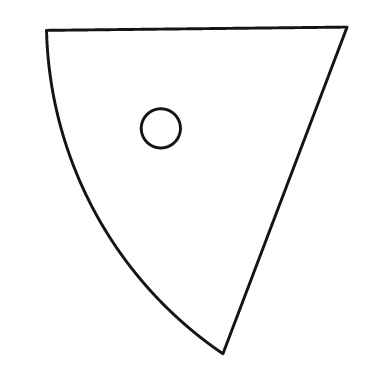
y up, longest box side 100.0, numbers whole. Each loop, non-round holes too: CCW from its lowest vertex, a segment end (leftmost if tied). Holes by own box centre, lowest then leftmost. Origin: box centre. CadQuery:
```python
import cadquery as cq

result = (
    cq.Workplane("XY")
    .moveTo(8.0, -50.0)
    .lineTo(46.0, 50.0)
    .lineTo(-46.0, 49.0)
    .threePointArc((-31.0, -7.0), (8.0, -50.0))
    .close()
    .moveTo(-11.0, 19.0)
    .circle(6.0)
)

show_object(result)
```